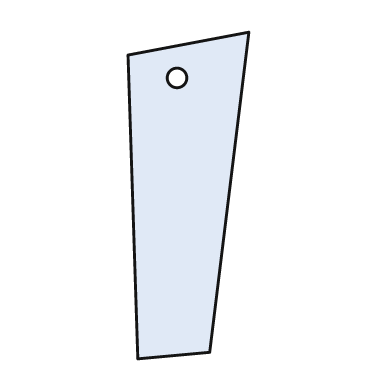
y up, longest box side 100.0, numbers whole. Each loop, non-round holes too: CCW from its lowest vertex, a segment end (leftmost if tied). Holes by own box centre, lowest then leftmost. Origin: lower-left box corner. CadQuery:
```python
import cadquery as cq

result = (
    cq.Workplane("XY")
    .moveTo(3.0, 0.0)
    .lineTo(25.0, 2.0)
    .lineTo(37.0, 100.0)
    .lineTo(0.0, 93.0)
    .close()
    .moveTo(15.0, 86.0)
    .circle(3.0)
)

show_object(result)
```